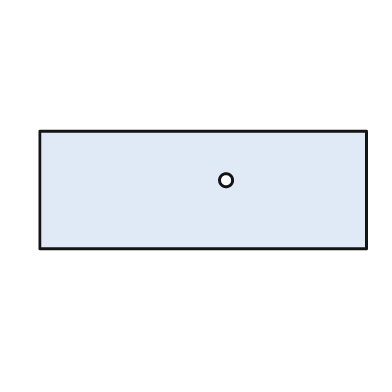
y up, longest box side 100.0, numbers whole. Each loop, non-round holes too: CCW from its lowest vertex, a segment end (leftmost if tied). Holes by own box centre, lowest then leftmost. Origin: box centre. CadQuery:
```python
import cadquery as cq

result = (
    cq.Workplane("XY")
    .moveTo(-50.0, -18.0)
    .lineTo(50.0, -18.0)
    .lineTo(50.0, 18.0)
    .lineTo(-50.0, 18.0)
    .close()
    .moveTo(7.0, 3.0)
    .circle(2.0)
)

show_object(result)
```